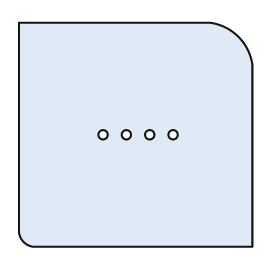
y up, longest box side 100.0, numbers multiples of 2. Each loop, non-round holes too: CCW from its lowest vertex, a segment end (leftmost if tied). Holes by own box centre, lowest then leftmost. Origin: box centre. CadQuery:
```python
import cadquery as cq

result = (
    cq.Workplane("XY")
    .moveTo(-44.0, -48.0)
    .lineTo(50.0, -48.0)
    .lineTo(50.0, 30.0)
    .threePointArc((44.0, 42.0), (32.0, 48.0))
    .lineTo(-50.0, 48.0)
    .lineTo(-50.0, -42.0)
    .threePointArc((-48.0, -46.0), (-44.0, -48.0))
    .close()
    .moveTo(-14.0, 0.0)
    .circle(2.0)
    .moveTo(-4.0, 0.0)
    .circle(2.0)
    .moveTo(6.0, 0.0)
    .circle(2.0)
    .moveTo(16.0, 0.0)
    .circle(2.0)
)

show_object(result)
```